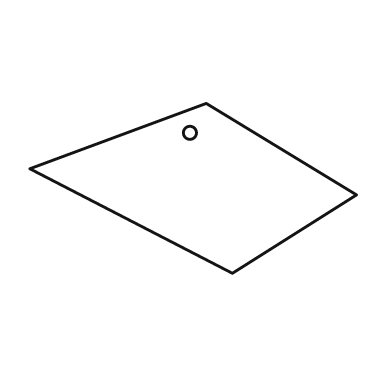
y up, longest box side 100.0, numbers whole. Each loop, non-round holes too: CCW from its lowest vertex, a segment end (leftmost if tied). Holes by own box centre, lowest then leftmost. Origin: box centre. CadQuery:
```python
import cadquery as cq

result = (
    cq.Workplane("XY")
    .moveTo(12.0, -26.0)
    .lineTo(50.0, -2.0)
    .lineTo(4.0, 26.0)
    .lineTo(-50.0, 6.0)
    .close()
    .moveTo(-1.0, 17.0)
    .circle(2.0)
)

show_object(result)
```